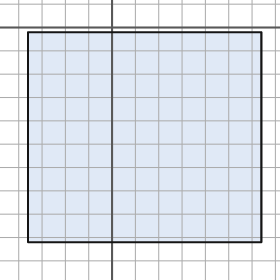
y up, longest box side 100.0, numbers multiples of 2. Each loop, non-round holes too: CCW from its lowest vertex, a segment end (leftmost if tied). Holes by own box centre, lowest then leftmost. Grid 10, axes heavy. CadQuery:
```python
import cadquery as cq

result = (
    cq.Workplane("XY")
    .moveTo(-36.0, -92.0)
    .lineTo(64.0, -92.0)
    .lineTo(64.0, -2.0)
    .lineTo(-36.0, -2.0)
    .close()
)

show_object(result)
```